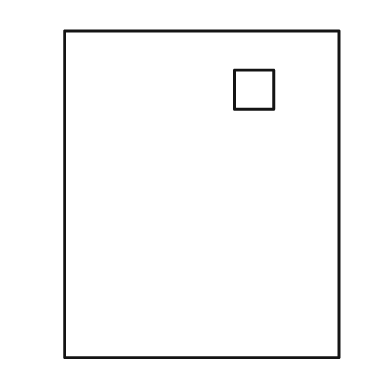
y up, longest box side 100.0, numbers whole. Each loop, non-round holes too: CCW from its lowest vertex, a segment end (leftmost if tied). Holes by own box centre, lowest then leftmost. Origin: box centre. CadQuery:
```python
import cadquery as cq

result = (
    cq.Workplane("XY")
    .moveTo(-42.0, -50.0)
    .lineTo(42.0, -50.0)
    .lineTo(42.0, 50.0)
    .lineTo(-42.0, 50.0)
    .close()
    .moveTo(10.0, 26.0)
    .lineTo(22.0, 26.0)
    .lineTo(22.0, 38.0)
    .lineTo(10.0, 38.0)
    .close()
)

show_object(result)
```